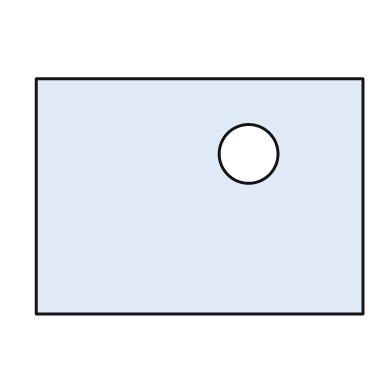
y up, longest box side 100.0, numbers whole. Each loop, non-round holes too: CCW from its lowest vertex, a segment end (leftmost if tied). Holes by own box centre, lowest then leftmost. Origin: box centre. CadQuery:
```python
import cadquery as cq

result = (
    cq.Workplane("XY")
    .moveTo(-50.0, -36.0)
    .lineTo(50.0, -36.0)
    .lineTo(50.0, 36.0)
    .lineTo(-50.0, 36.0)
    .close()
    .moveTo(15.0, 13.0)
    .circle(9.0)
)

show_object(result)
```